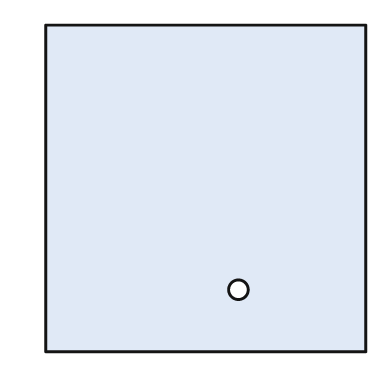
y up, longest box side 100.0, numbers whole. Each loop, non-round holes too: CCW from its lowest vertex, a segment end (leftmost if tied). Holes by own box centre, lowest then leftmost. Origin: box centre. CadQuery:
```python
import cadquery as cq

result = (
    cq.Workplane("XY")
    .moveTo(-49.0, -50.0)
    .lineTo(49.0, -50.0)
    .lineTo(49.0, 50.0)
    .lineTo(-49.0, 50.0)
    .close()
    .moveTo(10.0, -31.0)
    .circle(3.0)
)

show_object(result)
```